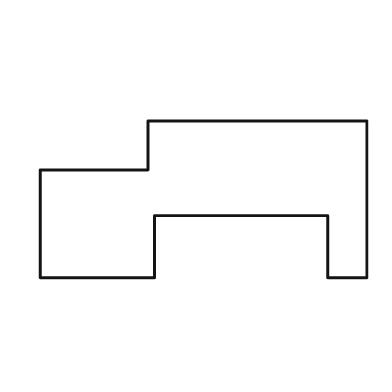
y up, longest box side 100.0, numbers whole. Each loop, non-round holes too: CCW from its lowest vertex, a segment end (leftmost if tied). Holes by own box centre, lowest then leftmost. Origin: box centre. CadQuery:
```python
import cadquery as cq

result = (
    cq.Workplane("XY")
    .moveTo(-50.0, -24.0)
    .lineTo(-15.0, -24.0)
    .lineTo(-15.0, -5.0)
    .lineTo(38.0, -5.0)
    .lineTo(38.0, -24.0)
    .lineTo(50.0, -24.0)
    .lineTo(50.0, 24.0)
    .lineTo(-17.0, 24.0)
    .lineTo(-17.0, 9.0)
    .lineTo(-50.0, 9.0)
    .close()
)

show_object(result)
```